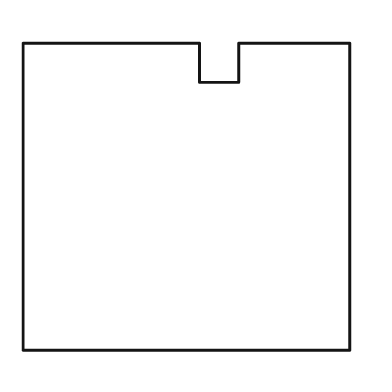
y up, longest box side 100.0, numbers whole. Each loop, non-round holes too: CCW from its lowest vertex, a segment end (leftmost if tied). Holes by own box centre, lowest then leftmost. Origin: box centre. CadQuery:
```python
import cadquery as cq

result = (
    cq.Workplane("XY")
    .moveTo(-50.0, -47.0)
    .lineTo(50.0, -47.0)
    .lineTo(50.0, 47.0)
    .lineTo(16.0, 47.0)
    .lineTo(16.0, 35.0)
    .lineTo(4.0, 35.0)
    .lineTo(4.0, 47.0)
    .lineTo(-50.0, 47.0)
    .close()
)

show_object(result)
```